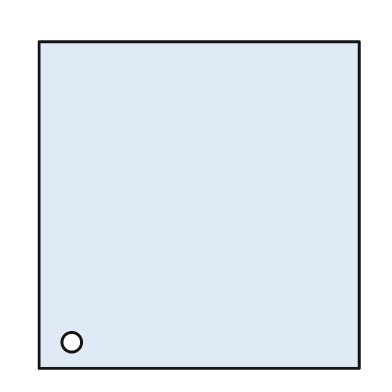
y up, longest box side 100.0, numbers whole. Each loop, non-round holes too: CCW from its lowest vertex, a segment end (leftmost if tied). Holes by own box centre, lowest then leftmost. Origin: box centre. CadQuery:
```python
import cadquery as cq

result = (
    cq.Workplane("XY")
    .moveTo(-49.0, -50.0)
    .lineTo(49.0, -50.0)
    .lineTo(49.0, 50.0)
    .lineTo(-49.0, 50.0)
    .close()
    .moveTo(-39.0, -42.0)
    .circle(3.0)
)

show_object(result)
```